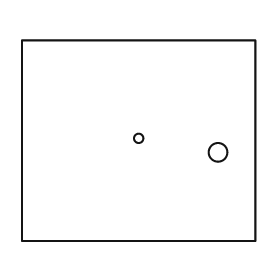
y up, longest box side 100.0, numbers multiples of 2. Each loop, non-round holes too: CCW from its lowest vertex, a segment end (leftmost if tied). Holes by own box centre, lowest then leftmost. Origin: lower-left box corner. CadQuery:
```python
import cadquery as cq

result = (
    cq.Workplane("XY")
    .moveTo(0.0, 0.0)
    .lineTo(100.0, 0.0)
    .lineTo(100.0, 86.0)
    .lineTo(0.0, 86.0)
    .close()
    .moveTo(84.0, 38.0)
    .circle(4.0)
    .moveTo(50.0, 44.0)
    .circle(2.0)
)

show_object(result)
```